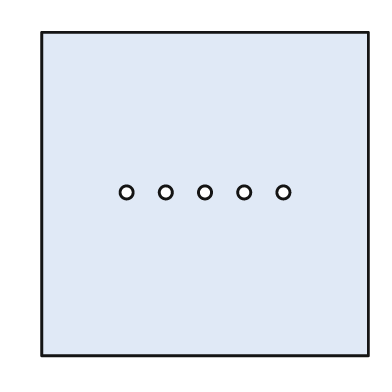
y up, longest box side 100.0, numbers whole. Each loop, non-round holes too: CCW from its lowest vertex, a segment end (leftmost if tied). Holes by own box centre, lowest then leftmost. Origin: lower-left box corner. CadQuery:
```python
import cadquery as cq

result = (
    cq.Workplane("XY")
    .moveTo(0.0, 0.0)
    .lineTo(100.0, 0.0)
    .lineTo(100.0, 99.0)
    .lineTo(0.0, 99.0)
    .close()
    .moveTo(26.0, 50.0)
    .circle(2.0)
    .moveTo(38.0, 50.0)
    .circle(2.0)
    .moveTo(50.0, 50.0)
    .circle(2.0)
    .moveTo(62.0, 50.0)
    .circle(2.0)
    .moveTo(74.0, 50.0)
    .circle(2.0)
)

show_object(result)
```